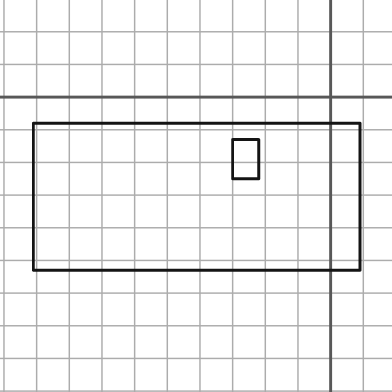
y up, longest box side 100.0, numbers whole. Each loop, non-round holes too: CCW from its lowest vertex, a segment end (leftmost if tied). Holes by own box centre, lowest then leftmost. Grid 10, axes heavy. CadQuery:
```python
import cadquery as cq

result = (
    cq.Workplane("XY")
    .moveTo(-91.0, -53.0)
    .lineTo(9.0, -53.0)
    .lineTo(9.0, -8.0)
    .lineTo(-91.0, -8.0)
    .close()
    .moveTo(-30.0, -25.0)
    .lineTo(-22.0, -25.0)
    .lineTo(-22.0, -13.0)
    .lineTo(-30.0, -13.0)
    .close()
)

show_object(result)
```